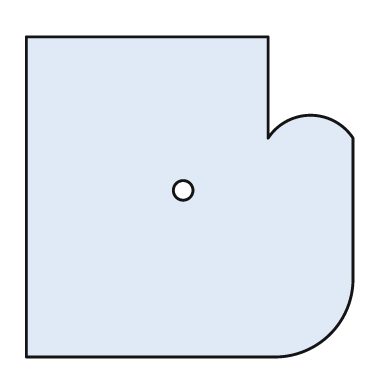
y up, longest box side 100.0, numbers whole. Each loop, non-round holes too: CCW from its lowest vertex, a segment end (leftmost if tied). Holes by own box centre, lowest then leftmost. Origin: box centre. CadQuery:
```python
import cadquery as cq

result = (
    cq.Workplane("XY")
    .moveTo(-50.0, -49.0)
    .lineTo(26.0, -49.0)
    .threePointArc((43.0, -42.0), (50.0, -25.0))
    .lineTo(50.0, 18.0)
    .threePointArc((37.0, 25.0), (24.0, 18.0))
    .lineTo(24.0, 49.0)
    .lineTo(-50.0, 49.0)
    .close()
    .moveTo(-2.0, 2.0)
    .circle(3.0)
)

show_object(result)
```